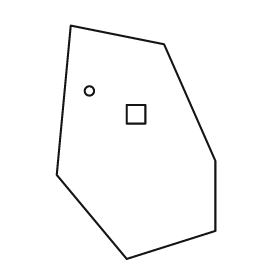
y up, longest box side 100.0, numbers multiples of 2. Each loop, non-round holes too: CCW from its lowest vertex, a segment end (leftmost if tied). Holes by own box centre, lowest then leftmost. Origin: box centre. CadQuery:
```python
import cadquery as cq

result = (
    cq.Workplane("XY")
    .moveTo(-4.0, -50.0)
    .lineTo(34.0, -38.0)
    .lineTo(34.0, -8.0)
    .lineTo(12.0, 42.0)
    .lineTo(-28.0, 50.0)
    .lineTo(-34.0, -14.0)
    .close()
    .moveTo(-4.0, 8.0)
    .lineTo(4.0, 8.0)
    .lineTo(4.0, 16.0)
    .lineTo(-4.0, 16.0)
    .close()
    .moveTo(-20.0, 22.0)
    .circle(2.0)
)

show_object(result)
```